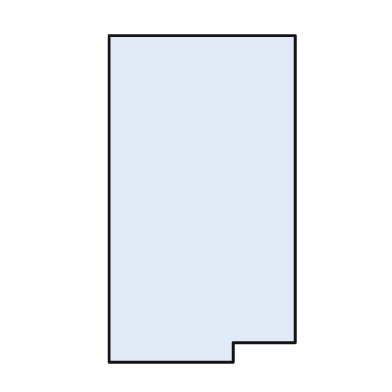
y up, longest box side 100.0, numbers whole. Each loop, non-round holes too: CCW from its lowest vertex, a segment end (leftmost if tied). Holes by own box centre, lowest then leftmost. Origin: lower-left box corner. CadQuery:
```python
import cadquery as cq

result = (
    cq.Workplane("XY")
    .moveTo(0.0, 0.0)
    .lineTo(38.0, 0.0)
    .lineTo(38.0, 6.0)
    .lineTo(57.0, 6.0)
    .lineTo(57.0, 100.0)
    .lineTo(0.0, 100.0)
    .close()
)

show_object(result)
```